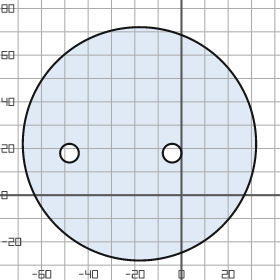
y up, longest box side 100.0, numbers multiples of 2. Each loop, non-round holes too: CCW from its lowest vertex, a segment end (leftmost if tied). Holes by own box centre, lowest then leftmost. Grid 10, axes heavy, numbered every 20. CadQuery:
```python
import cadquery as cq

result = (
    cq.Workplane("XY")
    .moveTo(-18.0, 22.0)
    .circle(50.0)
    .moveTo(-48.0, 18.0)
    .circle(4.0)
    .moveTo(-4.0, 18.0)
    .circle(4.0)
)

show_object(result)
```